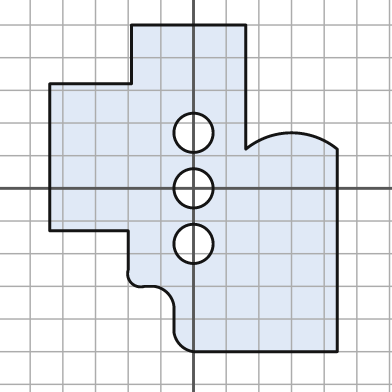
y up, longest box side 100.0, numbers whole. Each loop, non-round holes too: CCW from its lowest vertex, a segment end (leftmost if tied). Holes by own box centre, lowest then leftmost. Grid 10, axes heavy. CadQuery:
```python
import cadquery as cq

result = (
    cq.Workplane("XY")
    .moveTo(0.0, -50.0)
    .lineTo(44.0, -50.0)
    .lineTo(44.0, 12.0)
    .threePointArc((30.0, 17.0), (16.0, 12.0))
    .lineTo(16.0, 50.0)
    .lineTo(-19.0, 50.0)
    .lineTo(-19.0, 32.0)
    .lineTo(-44.0, 32.0)
    .lineTo(-44.0, -13.0)
    .lineTo(-20.0, -13.0)
    .lineTo(-20.0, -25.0)
    .threePointArc((-19.0, -29.0), (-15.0, -30.0))
    .lineTo(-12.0, -30.0)
    .threePointArc((-8.0, -32.0), (-6.0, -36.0))
    .lineTo(-6.0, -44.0)
    .threePointArc((-4.0, -48.0), (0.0, -50.0))
    .close()
    .moveTo(0.0, -17.0)
    .circle(6.0)
    .moveTo(0.0, 0.0)
    .circle(6.0)
    .moveTo(0.0, 17.0)
    .circle(6.0)
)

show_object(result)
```